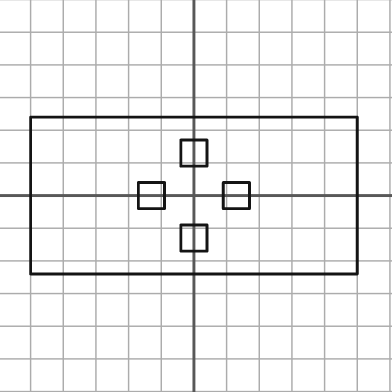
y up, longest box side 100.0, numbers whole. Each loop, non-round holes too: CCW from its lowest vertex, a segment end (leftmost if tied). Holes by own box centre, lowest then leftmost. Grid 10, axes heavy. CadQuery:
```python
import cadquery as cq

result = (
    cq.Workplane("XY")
    .moveTo(-50.0, -24.0)
    .lineTo(50.0, -24.0)
    .lineTo(50.0, 24.0)
    .lineTo(-50.0, 24.0)
    .close()
    .moveTo(-4.0, -17.0)
    .lineTo(4.0, -17.0)
    .lineTo(4.0, -9.0)
    .lineTo(-4.0, -9.0)
    .close()
    .moveTo(-17.0, -4.0)
    .lineTo(-9.0, -4.0)
    .lineTo(-9.0, 4.0)
    .lineTo(-17.0, 4.0)
    .close()
    .moveTo(9.0, -4.0)
    .lineTo(17.0, -4.0)
    .lineTo(17.0, 4.0)
    .lineTo(9.0, 4.0)
    .close()
    .moveTo(-4.0, 9.0)
    .lineTo(4.0, 9.0)
    .lineTo(4.0, 17.0)
    .lineTo(-4.0, 17.0)
    .close()
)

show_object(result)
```